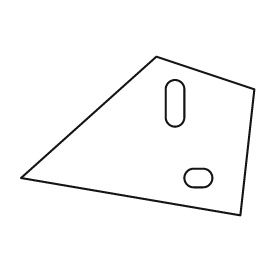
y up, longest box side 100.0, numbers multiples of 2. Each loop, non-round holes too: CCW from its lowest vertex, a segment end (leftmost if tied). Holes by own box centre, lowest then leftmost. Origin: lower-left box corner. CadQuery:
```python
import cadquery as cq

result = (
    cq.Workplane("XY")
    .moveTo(94.0, 0.0)
    .lineTo(100.0, 54.0)
    .lineTo(58.0, 68.0)
    .lineTo(0.0, 16.0)
    .close()
    .moveTo(74.0, 12.0)
    .lineTo(78.0, 12.0)
    .threePointArc((82.0, 16.0), (78.0, 20.0))
    .lineTo(74.0, 20.0)
    .threePointArc((70.0, 16.0), (74.0, 12.0))
    .close()
    .moveTo(62.0, 42.0)
    .threePointArc((66.0, 38.0), (70.0, 42.0))
    .lineTo(70.0, 54.0)
    .threePointArc((66.0, 58.0), (62.0, 54.0))
    .close()
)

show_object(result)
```